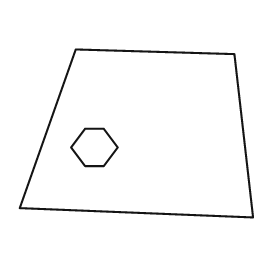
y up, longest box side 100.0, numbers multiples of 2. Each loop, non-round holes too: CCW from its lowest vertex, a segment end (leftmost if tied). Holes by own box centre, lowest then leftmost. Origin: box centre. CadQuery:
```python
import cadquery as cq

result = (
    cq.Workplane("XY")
    .moveTo(50.0, -36.0)
    .lineTo(42.0, 34.0)
    .lineTo(-26.0, 36.0)
    .lineTo(-50.0, -32.0)
    .close()
    .moveTo(-22.0, -14.0)
    .lineTo(-14.0, -14.0)
    .lineTo(-8.0, -6.0)
    .lineTo(-14.0, 2.0)
    .lineTo(-22.0, 2.0)
    .lineTo(-28.0, -6.0)
    .close()
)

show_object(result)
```